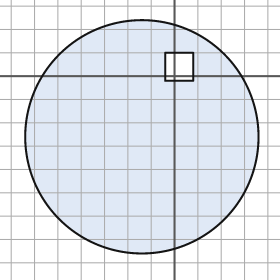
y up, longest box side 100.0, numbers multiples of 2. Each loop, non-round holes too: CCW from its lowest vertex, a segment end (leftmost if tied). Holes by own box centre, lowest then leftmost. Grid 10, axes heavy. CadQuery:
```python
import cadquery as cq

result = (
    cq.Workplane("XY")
    .moveTo(-14.0, -26.0)
    .circle(50.0)
    .moveTo(-4.0, -2.0)
    .lineTo(8.0, -2.0)
    .lineTo(8.0, 10.0)
    .lineTo(-4.0, 10.0)
    .close()
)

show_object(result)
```